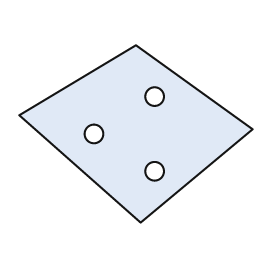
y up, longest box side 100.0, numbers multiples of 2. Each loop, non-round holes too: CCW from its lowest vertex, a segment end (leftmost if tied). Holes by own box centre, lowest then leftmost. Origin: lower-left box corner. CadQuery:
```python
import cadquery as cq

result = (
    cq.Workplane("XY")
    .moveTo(52.0, 0.0)
    .lineTo(100.0, 40.0)
    .lineTo(50.0, 76.0)
    .lineTo(0.0, 46.0)
    .close()
    .moveTo(58.0, 22.0)
    .circle(4.0)
    .moveTo(32.0, 38.0)
    .circle(4.0)
    .moveTo(58.0, 54.0)
    .circle(4.0)
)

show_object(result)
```